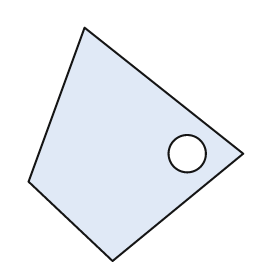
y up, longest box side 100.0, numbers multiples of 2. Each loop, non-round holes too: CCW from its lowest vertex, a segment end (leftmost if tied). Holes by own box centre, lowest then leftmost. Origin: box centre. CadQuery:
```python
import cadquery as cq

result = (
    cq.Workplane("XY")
    .moveTo(-10.0, -50.0)
    .lineTo(46.0, -4.0)
    .lineTo(-22.0, 50.0)
    .lineTo(-46.0, -16.0)
    .close()
    .moveTo(22.0, -4.0)
    .circle(8.0)
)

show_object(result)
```